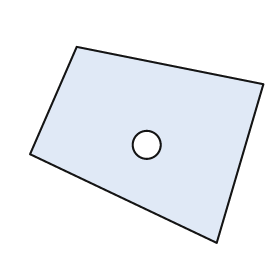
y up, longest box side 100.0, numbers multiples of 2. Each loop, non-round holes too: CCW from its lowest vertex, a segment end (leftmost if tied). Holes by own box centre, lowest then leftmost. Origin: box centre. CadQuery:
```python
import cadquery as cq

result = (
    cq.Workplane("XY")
    .moveTo(30.0, -42.0)
    .lineTo(50.0, 26.0)
    .lineTo(-30.0, 42.0)
    .lineTo(-50.0, -4.0)
    .close()
    .moveTo(0.0, 0.0)
    .circle(6.0)
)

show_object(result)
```